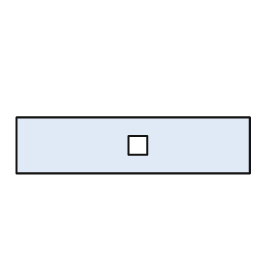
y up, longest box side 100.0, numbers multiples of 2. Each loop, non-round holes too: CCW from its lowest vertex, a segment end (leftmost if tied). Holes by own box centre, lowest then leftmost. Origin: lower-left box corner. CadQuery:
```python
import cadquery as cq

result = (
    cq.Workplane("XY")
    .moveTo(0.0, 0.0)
    .lineTo(100.0, 0.0)
    .lineTo(100.0, 24.0)
    .lineTo(0.0, 24.0)
    .close()
    .moveTo(48.0, 8.0)
    .lineTo(56.0, 8.0)
    .lineTo(56.0, 16.0)
    .lineTo(48.0, 16.0)
    .close()
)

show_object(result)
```